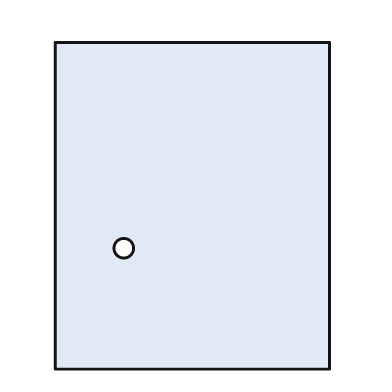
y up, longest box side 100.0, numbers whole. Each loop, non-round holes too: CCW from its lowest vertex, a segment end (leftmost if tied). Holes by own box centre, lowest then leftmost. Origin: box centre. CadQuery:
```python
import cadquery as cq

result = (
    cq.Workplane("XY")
    .moveTo(-42.0, -50.0)
    .lineTo(42.0, -50.0)
    .lineTo(42.0, 50.0)
    .lineTo(-42.0, 50.0)
    .close()
    .moveTo(-21.0, -13.0)
    .circle(3.0)
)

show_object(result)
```